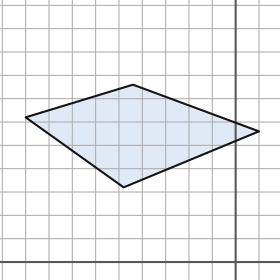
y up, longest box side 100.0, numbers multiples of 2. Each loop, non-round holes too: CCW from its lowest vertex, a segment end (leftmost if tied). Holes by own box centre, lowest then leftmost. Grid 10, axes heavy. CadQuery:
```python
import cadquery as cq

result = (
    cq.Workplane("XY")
    .moveTo(-48.0, 32.0)
    .lineTo(10.0, 56.0)
    .lineTo(-44.0, 76.0)
    .lineTo(-90.0, 62.0)
    .close()
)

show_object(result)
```